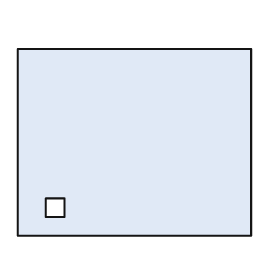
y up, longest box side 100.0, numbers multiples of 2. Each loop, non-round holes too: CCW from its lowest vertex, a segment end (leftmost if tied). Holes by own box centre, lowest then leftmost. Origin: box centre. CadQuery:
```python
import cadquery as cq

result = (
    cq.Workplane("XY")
    .moveTo(-50.0, -40.0)
    .lineTo(50.0, -40.0)
    .lineTo(50.0, 40.0)
    .lineTo(-50.0, 40.0)
    .close()
    .moveTo(-38.0, -32.0)
    .lineTo(-30.0, -32.0)
    .lineTo(-30.0, -24.0)
    .lineTo(-38.0, -24.0)
    .close()
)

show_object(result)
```